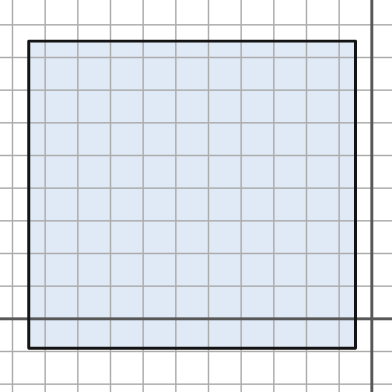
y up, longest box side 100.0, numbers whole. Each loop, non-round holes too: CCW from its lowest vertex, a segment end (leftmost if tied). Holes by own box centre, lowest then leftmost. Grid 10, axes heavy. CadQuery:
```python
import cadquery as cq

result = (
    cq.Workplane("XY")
    .moveTo(-105.0, -9.0)
    .lineTo(-5.0, -9.0)
    .lineTo(-5.0, 85.0)
    .lineTo(-105.0, 85.0)
    .close()
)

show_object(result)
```